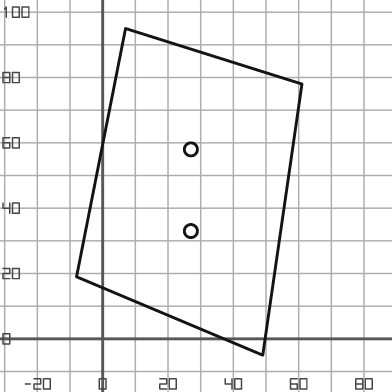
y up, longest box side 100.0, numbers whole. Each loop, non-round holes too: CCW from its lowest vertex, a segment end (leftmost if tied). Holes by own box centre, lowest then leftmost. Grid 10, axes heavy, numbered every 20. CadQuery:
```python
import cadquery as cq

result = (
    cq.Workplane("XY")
    .moveTo(49.0, -5.0)
    .lineTo(61.0, 78.0)
    .lineTo(7.0, 95.0)
    .lineTo(-8.0, 19.0)
    .close()
    .moveTo(27.0, 33.0)
    .circle(2.0)
    .moveTo(27.0, 58.0)
    .circle(2.0)
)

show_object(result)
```